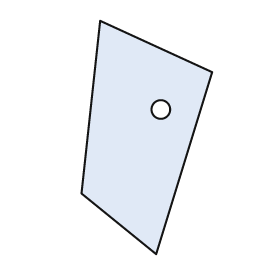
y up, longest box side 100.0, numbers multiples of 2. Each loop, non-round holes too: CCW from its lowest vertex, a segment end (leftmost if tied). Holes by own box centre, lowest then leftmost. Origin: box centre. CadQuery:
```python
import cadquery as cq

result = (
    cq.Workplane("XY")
    .moveTo(4.0, -50.0)
    .lineTo(28.0, 28.0)
    .lineTo(-20.0, 50.0)
    .lineTo(-28.0, -24.0)
    .close()
    .moveTo(6.0, 12.0)
    .circle(4.0)
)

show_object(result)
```